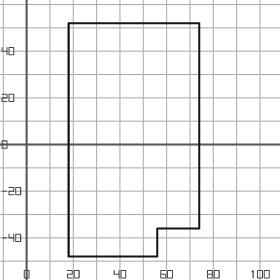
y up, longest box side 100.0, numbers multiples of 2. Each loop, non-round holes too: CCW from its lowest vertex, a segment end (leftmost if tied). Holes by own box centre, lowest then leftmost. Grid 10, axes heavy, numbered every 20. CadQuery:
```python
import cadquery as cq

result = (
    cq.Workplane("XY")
    .moveTo(18.0, -48.0)
    .lineTo(56.0, -48.0)
    .lineTo(56.0, -36.0)
    .lineTo(74.0, -36.0)
    .lineTo(74.0, 52.0)
    .lineTo(18.0, 52.0)
    .close()
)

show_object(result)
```